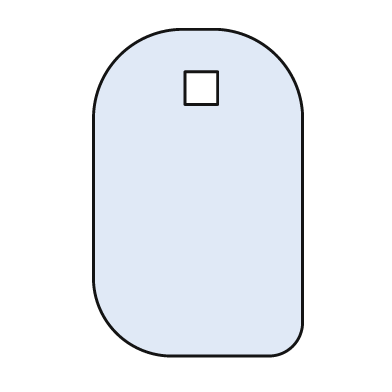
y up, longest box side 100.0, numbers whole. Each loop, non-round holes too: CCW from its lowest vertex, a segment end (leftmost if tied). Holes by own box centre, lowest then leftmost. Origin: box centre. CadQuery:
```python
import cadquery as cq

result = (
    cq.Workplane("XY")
    .moveTo(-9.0, -50.0)
    .lineTo(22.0, -50.0)
    .threePointArc((29.0, -47.0), (32.0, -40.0))
    .lineTo(32.0, 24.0)
    .threePointArc((24.0, 42.0), (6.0, 50.0))
    .lineTo(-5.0, 50.0)
    .threePointArc((-24.0, 42.0), (-32.0, 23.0))
    .lineTo(-32.0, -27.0)
    .threePointArc((-25.0, -43.0), (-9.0, -50.0))
    .close()
    .moveTo(-4.0, 27.0)
    .lineTo(6.0, 27.0)
    .lineTo(6.0, 37.0)
    .lineTo(-4.0, 37.0)
    .close()
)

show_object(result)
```